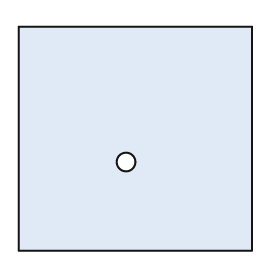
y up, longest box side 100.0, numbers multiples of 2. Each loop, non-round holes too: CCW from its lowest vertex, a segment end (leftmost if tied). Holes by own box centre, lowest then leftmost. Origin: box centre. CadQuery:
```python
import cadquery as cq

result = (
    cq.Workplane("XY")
    .moveTo(-50.0, -48.0)
    .lineTo(50.0, -48.0)
    .lineTo(50.0, 48.0)
    .lineTo(-50.0, 48.0)
    .close()
    .moveTo(-4.0, -10.0)
    .circle(4.0)
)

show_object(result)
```